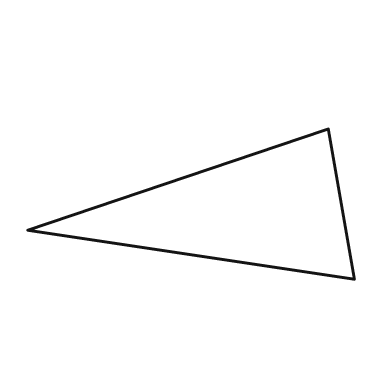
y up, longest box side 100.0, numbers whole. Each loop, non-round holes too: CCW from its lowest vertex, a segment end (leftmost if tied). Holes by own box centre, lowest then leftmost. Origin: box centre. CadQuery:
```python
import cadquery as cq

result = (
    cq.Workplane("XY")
    .moveTo(50.0, -23.0)
    .lineTo(42.0, 23.0)
    .lineTo(-50.0, -8.0)
    .close()
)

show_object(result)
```